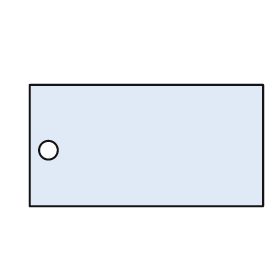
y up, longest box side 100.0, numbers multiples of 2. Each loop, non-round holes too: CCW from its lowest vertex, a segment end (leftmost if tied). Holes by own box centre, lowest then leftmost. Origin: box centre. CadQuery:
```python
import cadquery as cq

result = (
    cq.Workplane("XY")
    .moveTo(-50.0, -26.0)
    .lineTo(50.0, -26.0)
    .lineTo(50.0, 26.0)
    .lineTo(-50.0, 26.0)
    .close()
    .moveTo(-42.0, -2.0)
    .circle(4.0)
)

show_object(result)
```